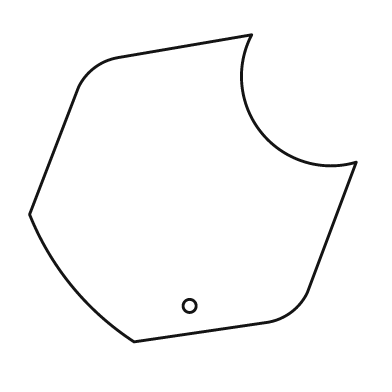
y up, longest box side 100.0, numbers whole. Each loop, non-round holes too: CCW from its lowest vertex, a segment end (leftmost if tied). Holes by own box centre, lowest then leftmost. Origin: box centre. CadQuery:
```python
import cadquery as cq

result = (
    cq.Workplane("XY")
    .moveTo(-18.0, -47.0)
    .lineTo(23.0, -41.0)
    .threePointArc((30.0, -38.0), (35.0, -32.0))
    .lineTo(50.0, 8.0)
    .threePointArc((21.0, 17.0), (18.0, 47.0))
    .lineTo(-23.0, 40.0)
    .threePointArc((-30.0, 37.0), (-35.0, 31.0))
    .lineTo(-50.0, -8.0)
    .threePointArc((-37.0, -30.0), (-18.0, -47.0))
    .close()
    .moveTo(-1.0, -36.0)
    .circle(2.0)
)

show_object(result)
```